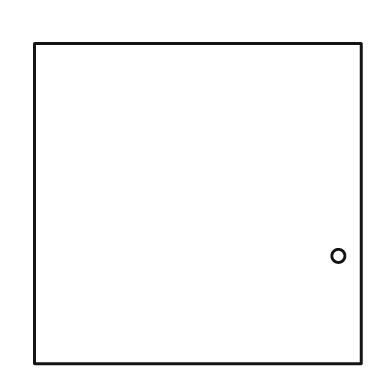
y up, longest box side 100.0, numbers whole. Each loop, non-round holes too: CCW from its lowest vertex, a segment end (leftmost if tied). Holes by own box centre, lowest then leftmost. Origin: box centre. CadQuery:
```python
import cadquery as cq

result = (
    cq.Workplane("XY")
    .moveTo(-50.0, -49.0)
    .lineTo(50.0, -49.0)
    .lineTo(50.0, 49.0)
    .lineTo(-50.0, 49.0)
    .close()
    .moveTo(43.0, -16.0)
    .circle(2.0)
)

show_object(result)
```